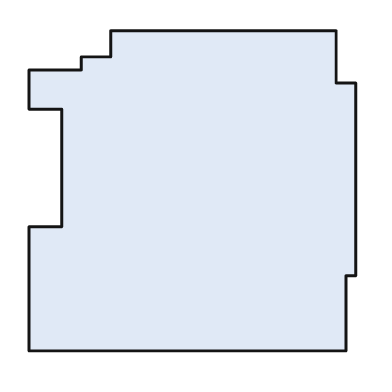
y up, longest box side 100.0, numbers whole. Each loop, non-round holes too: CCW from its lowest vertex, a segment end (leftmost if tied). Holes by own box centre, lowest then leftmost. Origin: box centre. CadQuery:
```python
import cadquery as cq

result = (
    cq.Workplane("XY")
    .moveTo(-50.0, -49.0)
    .lineTo(47.0, -49.0)
    .lineTo(47.0, -26.0)
    .lineTo(50.0, -26.0)
    .lineTo(50.0, 33.0)
    .lineTo(44.0, 33.0)
    .lineTo(44.0, 49.0)
    .lineTo(-25.0, 49.0)
    .lineTo(-25.0, 41.0)
    .lineTo(-34.0, 41.0)
    .lineTo(-34.0, 37.0)
    .lineTo(-50.0, 37.0)
    .lineTo(-50.0, 25.0)
    .lineTo(-40.0, 25.0)
    .lineTo(-40.0, -11.0)
    .lineTo(-50.0, -11.0)
    .close()
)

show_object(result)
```